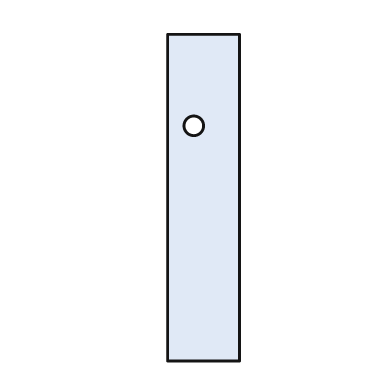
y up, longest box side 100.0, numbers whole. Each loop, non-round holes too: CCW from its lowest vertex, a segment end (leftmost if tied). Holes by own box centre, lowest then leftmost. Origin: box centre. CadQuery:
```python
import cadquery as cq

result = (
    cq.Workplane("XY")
    .moveTo(-11.0, -50.0)
    .lineTo(11.0, -50.0)
    .lineTo(11.0, 50.0)
    .lineTo(-11.0, 50.0)
    .close()
    .moveTo(-3.0, 22.0)
    .circle(3.0)
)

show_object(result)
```